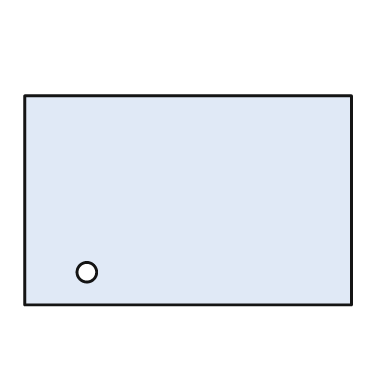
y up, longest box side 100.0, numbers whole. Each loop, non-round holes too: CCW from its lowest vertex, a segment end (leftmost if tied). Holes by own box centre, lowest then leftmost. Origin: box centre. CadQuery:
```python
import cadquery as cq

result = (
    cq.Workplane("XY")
    .moveTo(-50.0, -32.0)
    .lineTo(50.0, -32.0)
    .lineTo(50.0, 32.0)
    .lineTo(-50.0, 32.0)
    .close()
    .moveTo(-31.0, -22.0)
    .circle(3.0)
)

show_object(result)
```